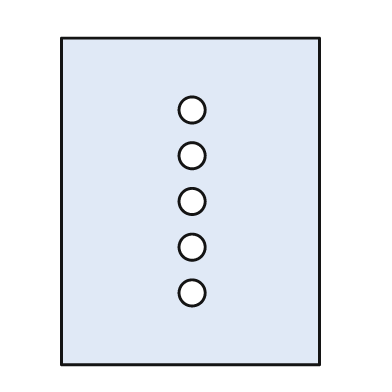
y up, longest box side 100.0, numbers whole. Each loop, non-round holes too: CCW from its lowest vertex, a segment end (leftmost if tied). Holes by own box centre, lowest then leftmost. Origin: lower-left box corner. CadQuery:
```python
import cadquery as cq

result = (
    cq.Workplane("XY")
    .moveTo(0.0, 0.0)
    .lineTo(79.0, 0.0)
    .lineTo(79.0, 100.0)
    .lineTo(0.0, 100.0)
    .close()
    .moveTo(40.0, 22.0)
    .circle(4.0)
    .moveTo(40.0, 36.0)
    .circle(4.0)
    .moveTo(40.0, 50.0)
    .circle(4.0)
    .moveTo(40.0, 64.0)
    .circle(4.0)
    .moveTo(40.0, 78.0)
    .circle(4.0)
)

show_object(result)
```